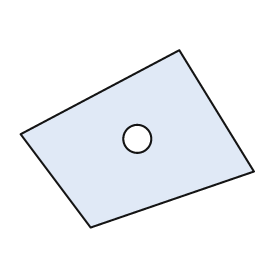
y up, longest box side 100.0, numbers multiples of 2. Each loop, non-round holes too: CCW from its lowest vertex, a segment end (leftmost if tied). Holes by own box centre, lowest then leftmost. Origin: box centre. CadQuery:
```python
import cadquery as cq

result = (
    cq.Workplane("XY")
    .moveTo(-20.0, -38.0)
    .lineTo(50.0, -14.0)
    .lineTo(18.0, 38.0)
    .lineTo(-50.0, 2.0)
    .close()
    .moveTo(0.0, 0.0)
    .circle(6.0)
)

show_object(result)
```